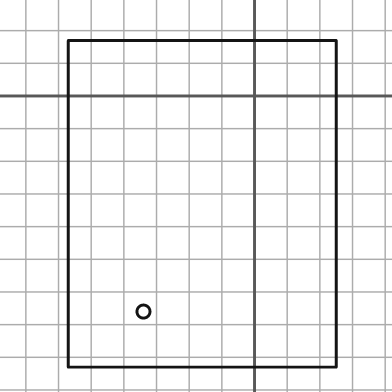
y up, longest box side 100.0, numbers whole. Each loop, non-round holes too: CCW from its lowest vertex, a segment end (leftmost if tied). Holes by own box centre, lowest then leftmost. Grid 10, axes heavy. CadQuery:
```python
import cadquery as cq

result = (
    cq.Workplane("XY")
    .moveTo(-57.0, -83.0)
    .lineTo(25.0, -83.0)
    .lineTo(25.0, 17.0)
    .lineTo(-57.0, 17.0)
    .close()
    .moveTo(-34.0, -66.0)
    .circle(2.0)
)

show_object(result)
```